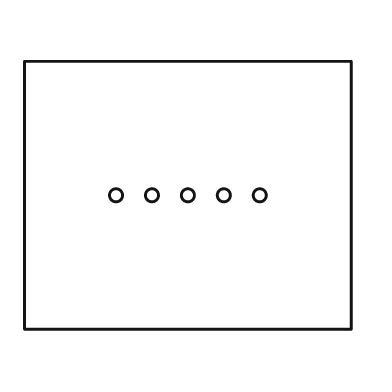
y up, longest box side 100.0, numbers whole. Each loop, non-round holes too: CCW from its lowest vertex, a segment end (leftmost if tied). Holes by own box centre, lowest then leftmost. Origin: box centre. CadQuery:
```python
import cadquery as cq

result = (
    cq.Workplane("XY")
    .moveTo(-50.0, -41.0)
    .lineTo(50.0, -41.0)
    .lineTo(50.0, 41.0)
    .lineTo(-50.0, 41.0)
    .close()
    .moveTo(-22.0, 0.0)
    .circle(2.0)
    .moveTo(-11.0, 0.0)
    .circle(2.0)
    .moveTo(0.0, 0.0)
    .circle(2.0)
    .moveTo(11.0, 0.0)
    .circle(2.0)
    .moveTo(22.0, 0.0)
    .circle(2.0)
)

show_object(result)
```